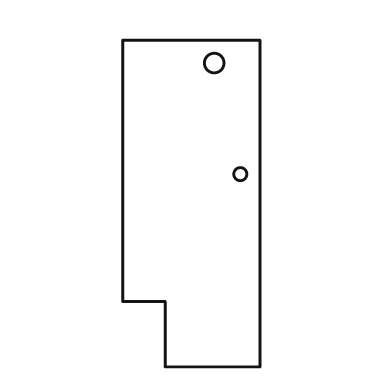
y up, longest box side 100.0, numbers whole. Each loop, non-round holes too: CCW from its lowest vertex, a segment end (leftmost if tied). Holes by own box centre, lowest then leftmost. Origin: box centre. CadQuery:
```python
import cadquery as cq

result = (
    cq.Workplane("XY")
    .moveTo(-8.0, -50.0)
    .lineTo(21.0, -50.0)
    .lineTo(21.0, 50.0)
    .lineTo(-21.0, 50.0)
    .lineTo(-21.0, -30.0)
    .lineTo(-8.0, -30.0)
    .close()
    .moveTo(15.0, 9.0)
    .circle(2.0)
    .moveTo(7.0, 43.0)
    .circle(3.0)
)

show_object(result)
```